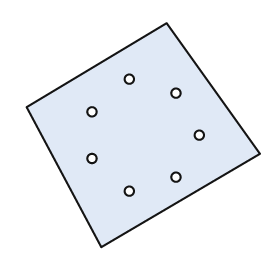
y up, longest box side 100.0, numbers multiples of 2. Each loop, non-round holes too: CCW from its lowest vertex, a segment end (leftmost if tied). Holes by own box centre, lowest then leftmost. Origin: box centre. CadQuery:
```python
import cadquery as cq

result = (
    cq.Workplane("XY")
    .moveTo(-18.0, -48.0)
    .lineTo(50.0, -8.0)
    .lineTo(10.0, 48.0)
    .lineTo(-50.0, 12.0)
    .close()
    .moveTo(-6.0, -24.0)
    .circle(2.0)
    .moveTo(14.0, -18.0)
    .circle(2.0)
    .moveTo(-22.0, -10.0)
    .circle(2.0)
    .moveTo(24.0, 0.0)
    .circle(2.0)
    .moveTo(-22.0, 10.0)
    .circle(2.0)
    .moveTo(14.0, 18.0)
    .circle(2.0)
    .moveTo(-6.0, 24.0)
    .circle(2.0)
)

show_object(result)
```